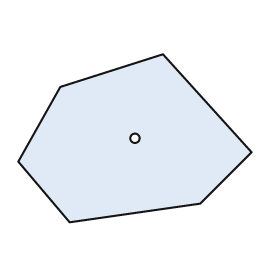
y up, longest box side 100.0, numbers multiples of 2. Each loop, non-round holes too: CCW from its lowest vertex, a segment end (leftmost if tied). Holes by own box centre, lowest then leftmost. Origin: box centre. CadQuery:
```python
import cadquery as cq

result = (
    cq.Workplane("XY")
    .moveTo(-28.0, -36.0)
    .lineTo(28.0, -28.0)
    .lineTo(50.0, -6.0)
    .lineTo(12.0, 36.0)
    .lineTo(-32.0, 22.0)
    .lineTo(-50.0, -10.0)
    .close()
    .moveTo(0.0, 0.0)
    .circle(2.0)
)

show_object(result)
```